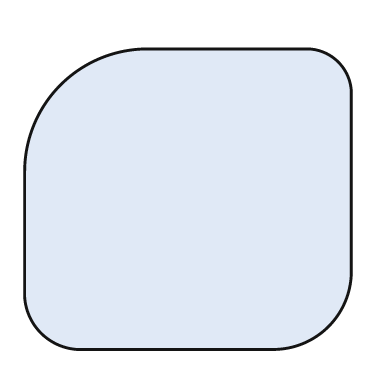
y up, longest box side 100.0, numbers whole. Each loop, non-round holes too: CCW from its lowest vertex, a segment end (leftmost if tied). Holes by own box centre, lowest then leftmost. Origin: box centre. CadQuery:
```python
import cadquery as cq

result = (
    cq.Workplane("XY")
    .moveTo(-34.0, -46.0)
    .lineTo(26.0, -46.0)
    .threePointArc((43.0, -39.0), (50.0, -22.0))
    .lineTo(50.0, 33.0)
    .threePointArc((46.0, 42.0), (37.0, 46.0))
    .lineTo(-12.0, 46.0)
    .threePointArc((-39.0, 35.0), (-50.0, 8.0))
    .lineTo(-50.0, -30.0)
    .threePointArc((-45.0, -41.0), (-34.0, -46.0))
    .close()
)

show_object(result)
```